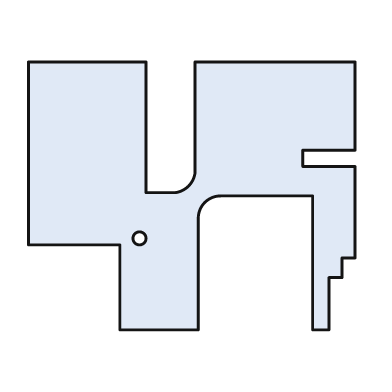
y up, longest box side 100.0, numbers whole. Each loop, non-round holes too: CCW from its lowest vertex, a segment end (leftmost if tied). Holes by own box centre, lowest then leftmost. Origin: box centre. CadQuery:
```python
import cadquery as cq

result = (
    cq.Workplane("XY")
    .moveTo(-22.0, -41.0)
    .lineTo(2.0, -41.0)
    .lineTo(2.0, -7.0)
    .threePointArc((4.0, -2.0), (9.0, 0.0))
    .lineTo(37.0, 0.0)
    .lineTo(37.0, -41.0)
    .lineTo(42.0, -41.0)
    .lineTo(42.0, -25.0)
    .lineTo(46.0, -25.0)
    .lineTo(46.0, -19.0)
    .lineTo(50.0, -19.0)
    .lineTo(50.0, 9.0)
    .lineTo(34.0, 9.0)
    .lineTo(34.0, 14.0)
    .lineTo(50.0, 14.0)
    .lineTo(50.0, 41.0)
    .lineTo(1.0, 41.0)
    .lineTo(1.0, 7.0)
    .threePointArc((-1.0, 3.0), (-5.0, 1.0))
    .lineTo(-14.0, 1.0)
    .lineTo(-14.0, 41.0)
    .lineTo(-50.0, 41.0)
    .lineTo(-50.0, -15.0)
    .lineTo(-22.0, -15.0)
    .close()
    .moveTo(-16.0, -13.0)
    .circle(2.0)
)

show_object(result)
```